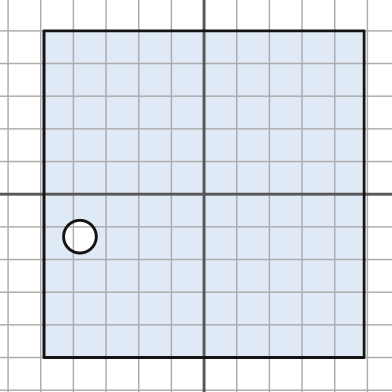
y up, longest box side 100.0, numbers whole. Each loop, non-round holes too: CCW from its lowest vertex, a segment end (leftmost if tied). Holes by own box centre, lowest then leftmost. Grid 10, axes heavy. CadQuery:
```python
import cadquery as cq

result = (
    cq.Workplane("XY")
    .moveTo(-49.0, -50.0)
    .lineTo(49.0, -50.0)
    .lineTo(49.0, 50.0)
    .lineTo(-49.0, 50.0)
    .close()
    .moveTo(-38.0, -13.0)
    .circle(5.0)
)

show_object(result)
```